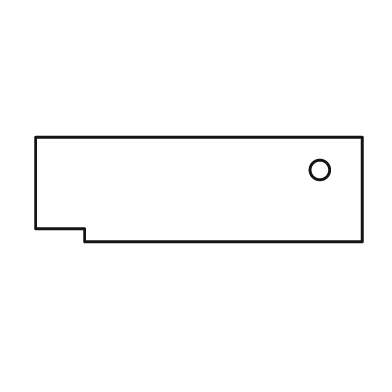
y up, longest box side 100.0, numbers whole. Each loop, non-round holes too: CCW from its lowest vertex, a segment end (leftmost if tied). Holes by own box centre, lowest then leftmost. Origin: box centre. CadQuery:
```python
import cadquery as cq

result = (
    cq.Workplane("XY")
    .moveTo(-35.0, -16.0)
    .lineTo(50.0, -16.0)
    .lineTo(50.0, 16.0)
    .lineTo(-50.0, 16.0)
    .lineTo(-50.0, -12.0)
    .lineTo(-35.0, -12.0)
    .close()
    .moveTo(37.0, 6.0)
    .circle(3.0)
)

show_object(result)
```